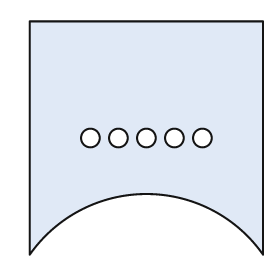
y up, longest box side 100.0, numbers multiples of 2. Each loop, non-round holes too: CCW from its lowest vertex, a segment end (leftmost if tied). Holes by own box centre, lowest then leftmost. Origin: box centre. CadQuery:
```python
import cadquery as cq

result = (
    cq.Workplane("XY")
    .moveTo(-50.0, -50.0)
    .threePointArc((0.0, -24.0), (50.0, -50.0))
    .lineTo(50.0, 50.0)
    .lineTo(-50.0, 50.0)
    .close()
    .moveTo(-24.0, 0.0)
    .circle(4.0)
    .moveTo(-12.0, 0.0)
    .circle(4.0)
    .moveTo(0.0, 0.0)
    .circle(4.0)
    .moveTo(12.0, 0.0)
    .circle(4.0)
    .moveTo(24.0, 0.0)
    .circle(4.0)
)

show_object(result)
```